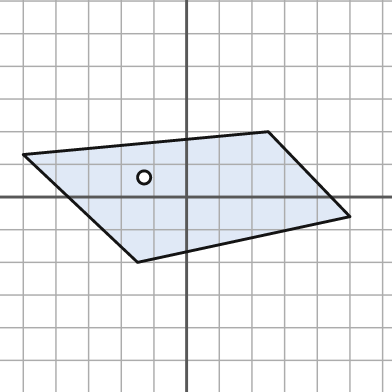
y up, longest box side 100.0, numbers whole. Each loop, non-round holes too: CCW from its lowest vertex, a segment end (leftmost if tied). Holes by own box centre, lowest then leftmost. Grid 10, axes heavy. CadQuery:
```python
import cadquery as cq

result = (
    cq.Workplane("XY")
    .moveTo(-15.0, -20.0)
    .lineTo(50.0, -6.0)
    .lineTo(25.0, 20.0)
    .lineTo(-50.0, 13.0)
    .close()
    .moveTo(-13.0, 6.0)
    .circle(2.0)
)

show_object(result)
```